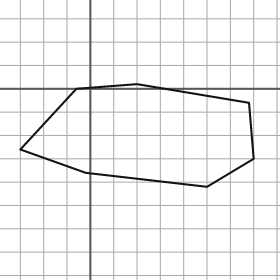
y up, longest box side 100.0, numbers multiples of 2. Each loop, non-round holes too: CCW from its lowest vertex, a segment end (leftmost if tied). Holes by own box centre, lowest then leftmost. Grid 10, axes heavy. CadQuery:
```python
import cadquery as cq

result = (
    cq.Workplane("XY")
    .moveTo(50.0, -42.0)
    .lineTo(70.0, -30.0)
    .lineTo(68.0, -6.0)
    .lineTo(20.0, 2.0)
    .lineTo(-6.0, 0.0)
    .lineTo(-30.0, -26.0)
    .lineTo(-2.0, -36.0)
    .close()
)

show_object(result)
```